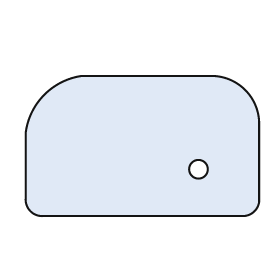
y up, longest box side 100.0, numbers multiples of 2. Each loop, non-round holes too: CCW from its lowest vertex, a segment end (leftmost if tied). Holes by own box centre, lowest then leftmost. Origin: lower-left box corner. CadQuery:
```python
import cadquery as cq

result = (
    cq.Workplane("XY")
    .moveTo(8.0, 0.0)
    .lineTo(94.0, 0.0)
    .threePointArc((98.0, 2.0), (100.0, 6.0))
    .lineTo(100.0, 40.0)
    .threePointArc((94.0, 54.0), (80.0, 60.0))
    .lineTo(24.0, 60.0)
    .threePointArc((8.0, 52.0), (0.0, 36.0))
    .lineTo(0.0, 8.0)
    .threePointArc((2.0, 2.0), (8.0, 0.0))
    .close()
    .moveTo(74.0, 20.0)
    .circle(4.0)
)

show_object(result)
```